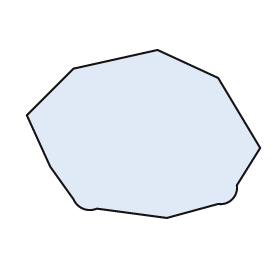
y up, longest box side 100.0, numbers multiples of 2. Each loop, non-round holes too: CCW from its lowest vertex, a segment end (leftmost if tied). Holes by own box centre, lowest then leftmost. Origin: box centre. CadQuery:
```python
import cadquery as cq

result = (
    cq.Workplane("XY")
    .moveTo(10.0, -36.0)
    .lineTo(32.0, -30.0)
    .threePointArc((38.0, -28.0), (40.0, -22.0))
    .lineTo(50.0, -6.0)
    .lineTo(32.0, 24.0)
    .lineTo(6.0, 36.0)
    .lineTo(-30.0, 28.0)
    .lineTo(-50.0, 8.0)
    .lineTo(-40.0, -14.0)
    .lineTo(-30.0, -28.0)
    .threePointArc((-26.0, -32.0), (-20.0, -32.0))
    .close()
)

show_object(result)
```